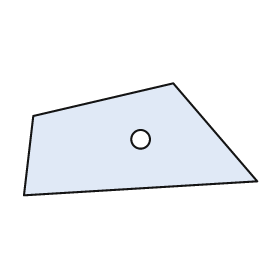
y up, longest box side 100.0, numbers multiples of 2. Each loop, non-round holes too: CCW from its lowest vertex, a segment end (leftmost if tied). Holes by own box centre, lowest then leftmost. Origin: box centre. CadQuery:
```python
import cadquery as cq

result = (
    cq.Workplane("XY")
    .moveTo(-50.0, -24.0)
    .lineTo(50.0, -18.0)
    .lineTo(14.0, 24.0)
    .lineTo(-46.0, 10.0)
    .close()
    .moveTo(0.0, 0.0)
    .circle(4.0)
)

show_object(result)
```